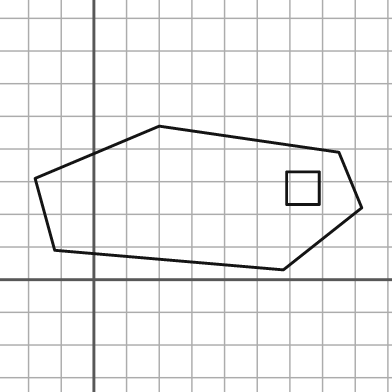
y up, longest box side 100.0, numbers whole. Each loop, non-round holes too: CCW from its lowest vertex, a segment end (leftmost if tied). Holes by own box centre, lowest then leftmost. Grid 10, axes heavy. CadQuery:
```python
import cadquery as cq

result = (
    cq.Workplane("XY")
    .moveTo(58.0, 3.0)
    .lineTo(82.0, 22.0)
    .lineTo(75.0, 39.0)
    .lineTo(20.0, 47.0)
    .lineTo(-18.0, 31.0)
    .lineTo(-12.0, 9.0)
    .close()
    .moveTo(59.0, 23.0)
    .lineTo(69.0, 23.0)
    .lineTo(69.0, 33.0)
    .lineTo(59.0, 33.0)
    .close()
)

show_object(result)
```